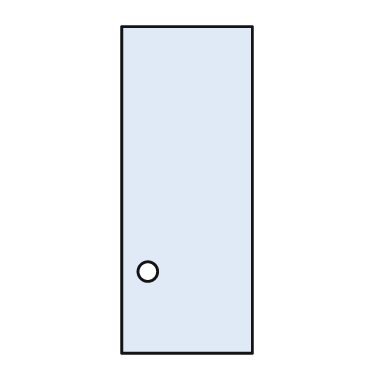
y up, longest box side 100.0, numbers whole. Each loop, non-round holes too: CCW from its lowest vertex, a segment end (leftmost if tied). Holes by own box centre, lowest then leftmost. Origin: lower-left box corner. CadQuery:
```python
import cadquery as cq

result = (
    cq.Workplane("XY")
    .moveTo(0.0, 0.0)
    .lineTo(40.0, 0.0)
    .lineTo(40.0, 100.0)
    .lineTo(0.0, 100.0)
    .close()
    .moveTo(8.0, 25.0)
    .circle(3.0)
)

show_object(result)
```